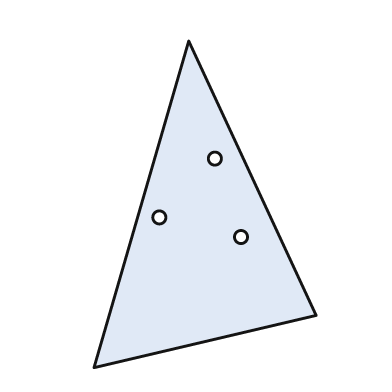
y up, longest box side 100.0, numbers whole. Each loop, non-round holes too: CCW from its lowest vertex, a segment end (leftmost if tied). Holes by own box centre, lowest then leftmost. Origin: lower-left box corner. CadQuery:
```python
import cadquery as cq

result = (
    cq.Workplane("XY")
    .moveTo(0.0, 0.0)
    .lineTo(68.0, 16.0)
    .lineTo(29.0, 100.0)
    .close()
    .moveTo(45.0, 40.0)
    .circle(2.0)
    .moveTo(20.0, 46.0)
    .circle(2.0)
    .moveTo(37.0, 64.0)
    .circle(2.0)
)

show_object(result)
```